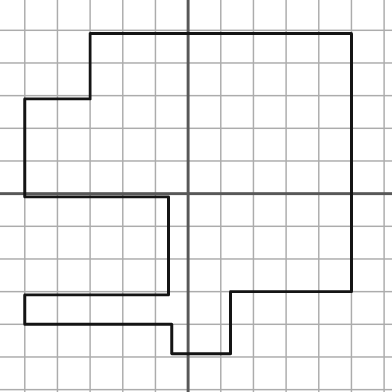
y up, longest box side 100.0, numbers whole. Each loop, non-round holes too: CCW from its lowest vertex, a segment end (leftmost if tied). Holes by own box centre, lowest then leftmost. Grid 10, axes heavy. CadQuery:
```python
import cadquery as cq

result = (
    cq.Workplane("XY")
    .moveTo(-5.0, -49.0)
    .lineTo(13.0, -49.0)
    .lineTo(13.0, -30.0)
    .lineTo(50.0, -30.0)
    .lineTo(50.0, 49.0)
    .lineTo(-30.0, 49.0)
    .lineTo(-30.0, 29.0)
    .lineTo(-50.0, 29.0)
    .lineTo(-50.0, -1.0)
    .lineTo(-6.0, -1.0)
    .lineTo(-6.0, -31.0)
    .lineTo(-50.0, -31.0)
    .lineTo(-50.0, -40.0)
    .lineTo(-5.0, -40.0)
    .close()
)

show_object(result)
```